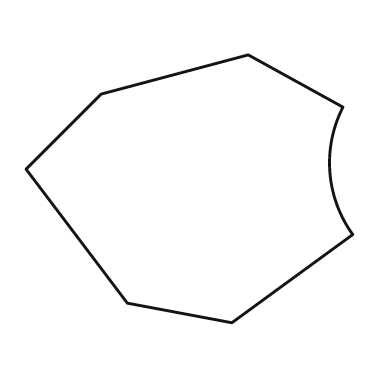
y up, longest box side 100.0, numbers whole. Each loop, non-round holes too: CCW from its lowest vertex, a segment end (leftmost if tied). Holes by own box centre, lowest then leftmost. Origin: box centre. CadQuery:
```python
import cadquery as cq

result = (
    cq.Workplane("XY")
    .moveTo(13.0, -41.0)
    .lineTo(50.0, -14.0)
    .threePointArc((43.0, 5.0), (47.0, 25.0))
    .lineTo(18.0, 41.0)
    .lineTo(-27.0, 29.0)
    .lineTo(-50.0, 6.0)
    .lineTo(-19.0, -35.0)
    .close()
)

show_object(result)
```